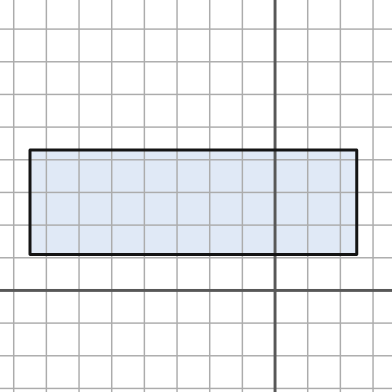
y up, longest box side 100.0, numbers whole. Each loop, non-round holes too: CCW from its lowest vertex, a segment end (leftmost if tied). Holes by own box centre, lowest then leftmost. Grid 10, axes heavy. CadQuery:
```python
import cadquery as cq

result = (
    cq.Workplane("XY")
    .moveTo(-75.0, 11.0)
    .lineTo(25.0, 11.0)
    .lineTo(25.0, 43.0)
    .lineTo(-75.0, 43.0)
    .close()
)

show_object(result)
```